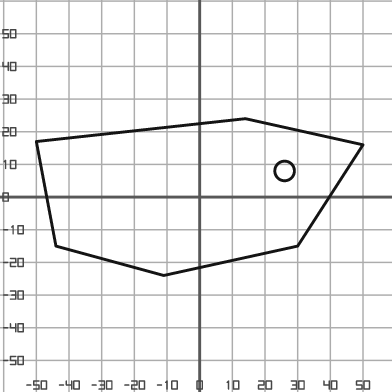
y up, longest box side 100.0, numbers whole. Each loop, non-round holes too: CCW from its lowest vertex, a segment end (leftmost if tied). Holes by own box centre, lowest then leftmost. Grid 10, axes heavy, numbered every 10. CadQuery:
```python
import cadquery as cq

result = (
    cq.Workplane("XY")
    .moveTo(-11.0, -24.0)
    .lineTo(30.0, -15.0)
    .lineTo(50.0, 16.0)
    .lineTo(14.0, 24.0)
    .lineTo(-50.0, 17.0)
    .lineTo(-44.0, -15.0)
    .close()
    .moveTo(26.0, 8.0)
    .circle(3.0)
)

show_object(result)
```